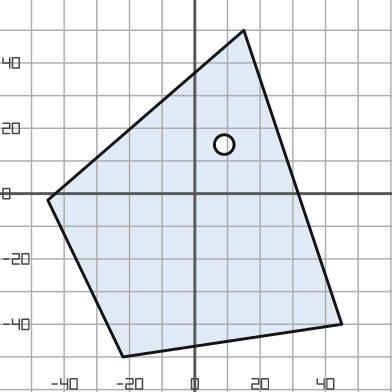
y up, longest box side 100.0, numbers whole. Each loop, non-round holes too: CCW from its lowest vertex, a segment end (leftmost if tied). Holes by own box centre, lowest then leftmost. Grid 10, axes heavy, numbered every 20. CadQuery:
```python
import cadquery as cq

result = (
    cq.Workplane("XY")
    .moveTo(-22.0, -50.0)
    .lineTo(45.0, -40.0)
    .lineTo(15.0, 50.0)
    .lineTo(-45.0, -2.0)
    .close()
    .moveTo(9.0, 15.0)
    .circle(3.0)
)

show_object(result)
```